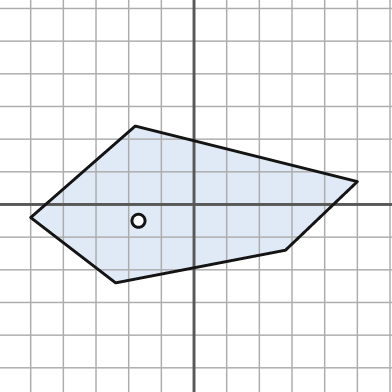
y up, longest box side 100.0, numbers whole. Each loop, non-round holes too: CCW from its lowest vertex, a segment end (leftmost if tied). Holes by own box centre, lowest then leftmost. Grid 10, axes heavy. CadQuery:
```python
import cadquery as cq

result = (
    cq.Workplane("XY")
    .moveTo(-24.0, -24.0)
    .lineTo(28.0, -14.0)
    .lineTo(50.0, 7.0)
    .lineTo(-18.0, 24.0)
    .lineTo(-50.0, -4.0)
    .close()
    .moveTo(-17.0, -5.0)
    .circle(2.0)
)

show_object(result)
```